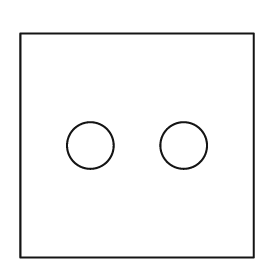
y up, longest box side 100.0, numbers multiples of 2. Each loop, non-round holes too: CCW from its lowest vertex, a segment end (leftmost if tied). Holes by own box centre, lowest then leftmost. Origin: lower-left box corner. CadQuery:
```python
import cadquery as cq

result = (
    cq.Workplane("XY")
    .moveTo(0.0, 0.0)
    .lineTo(100.0, 0.0)
    .lineTo(100.0, 96.0)
    .lineTo(0.0, 96.0)
    .close()
    .moveTo(30.0, 48.0)
    .circle(10.0)
    .moveTo(70.0, 48.0)
    .circle(10.0)
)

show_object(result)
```